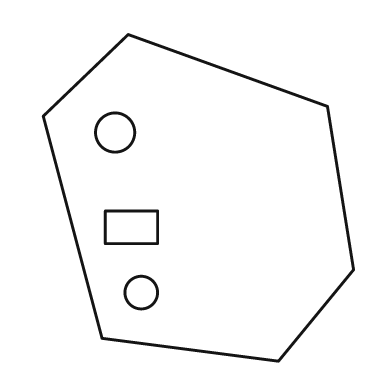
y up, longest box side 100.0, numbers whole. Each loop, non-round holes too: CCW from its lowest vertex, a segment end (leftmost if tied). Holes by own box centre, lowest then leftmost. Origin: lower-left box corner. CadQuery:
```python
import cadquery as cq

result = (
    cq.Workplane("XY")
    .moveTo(72.0, 0.0)
    .lineTo(95.0, 28.0)
    .lineTo(87.0, 78.0)
    .lineTo(26.0, 100.0)
    .lineTo(0.0, 75.0)
    .lineTo(18.0, 7.0)
    .close()
    .moveTo(30.0, 21.0)
    .circle(5.0)
    .moveTo(19.0, 36.0)
    .lineTo(35.0, 36.0)
    .lineTo(35.0, 46.0)
    .lineTo(19.0, 46.0)
    .close()
    .moveTo(22.0, 70.0)
    .circle(6.0)
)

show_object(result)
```